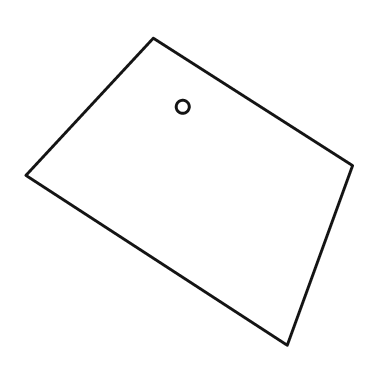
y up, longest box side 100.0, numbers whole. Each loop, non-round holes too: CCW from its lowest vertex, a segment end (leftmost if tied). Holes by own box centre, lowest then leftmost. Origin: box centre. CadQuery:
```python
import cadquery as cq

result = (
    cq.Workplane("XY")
    .moveTo(30.0, -47.0)
    .lineTo(50.0, 8.0)
    .lineTo(-11.0, 47.0)
    .lineTo(-50.0, 5.0)
    .close()
    .moveTo(-2.0, 26.0)
    .circle(2.0)
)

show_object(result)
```